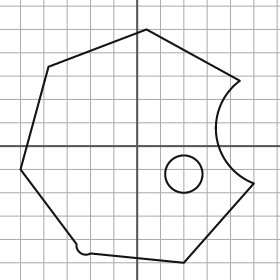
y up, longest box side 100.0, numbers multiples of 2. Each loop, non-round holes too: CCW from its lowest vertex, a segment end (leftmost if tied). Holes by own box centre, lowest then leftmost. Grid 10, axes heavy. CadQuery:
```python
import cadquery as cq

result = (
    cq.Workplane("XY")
    .moveTo(20.0, -50.0)
    .lineTo(50.0, -16.0)
    .threePointArc((34.0, 4.0), (44.0, 28.0))
    .lineTo(4.0, 50.0)
    .lineTo(-38.0, 34.0)
    .lineTo(-50.0, -10.0)
    .lineTo(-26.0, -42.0)
    .threePointArc((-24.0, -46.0), (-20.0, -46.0))
    .close()
    .moveTo(20.0, -12.0)
    .circle(8.0)
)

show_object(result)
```